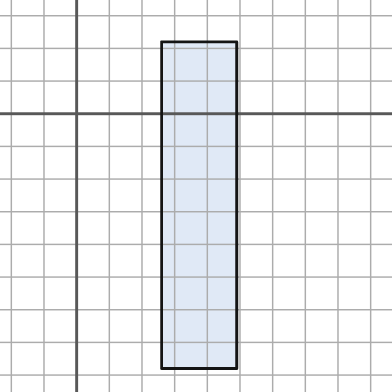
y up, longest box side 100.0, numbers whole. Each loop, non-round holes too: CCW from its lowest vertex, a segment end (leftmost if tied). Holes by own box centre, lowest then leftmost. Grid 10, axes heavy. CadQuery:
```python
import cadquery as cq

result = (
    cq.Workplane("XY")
    .moveTo(26.0, -78.0)
    .lineTo(49.0, -78.0)
    .lineTo(49.0, 22.0)
    .lineTo(26.0, 22.0)
    .close()
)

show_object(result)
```